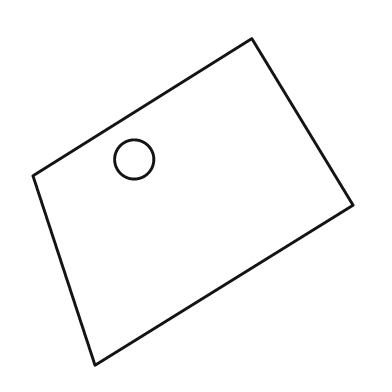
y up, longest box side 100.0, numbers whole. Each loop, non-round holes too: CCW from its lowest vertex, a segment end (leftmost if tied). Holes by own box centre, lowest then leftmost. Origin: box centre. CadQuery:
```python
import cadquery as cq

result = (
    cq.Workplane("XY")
    .moveTo(-30.0, -50.0)
    .lineTo(49.0, -1.0)
    .lineTo(18.0, 50.0)
    .lineTo(-49.0, 8.0)
    .close()
    .moveTo(-18.0, 13.0)
    .circle(6.0)
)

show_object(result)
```